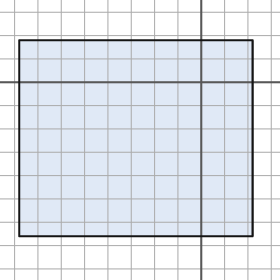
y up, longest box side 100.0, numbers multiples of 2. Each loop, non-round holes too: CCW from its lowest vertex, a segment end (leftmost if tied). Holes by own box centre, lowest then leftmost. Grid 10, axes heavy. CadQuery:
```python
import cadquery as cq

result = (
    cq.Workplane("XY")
    .moveTo(-78.0, -66.0)
    .lineTo(22.0, -66.0)
    .lineTo(22.0, 18.0)
    .lineTo(-78.0, 18.0)
    .close()
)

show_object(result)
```